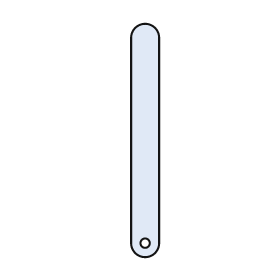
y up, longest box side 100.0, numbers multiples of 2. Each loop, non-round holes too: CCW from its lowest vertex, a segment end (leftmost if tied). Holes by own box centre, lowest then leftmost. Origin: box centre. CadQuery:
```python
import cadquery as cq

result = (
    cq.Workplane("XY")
    .moveTo(-6.0, -44.0)
    .threePointArc((0.0, -50.0), (6.0, -44.0))
    .lineTo(6.0, 44.0)
    .threePointArc((0.0, 50.0), (-6.0, 44.0))
    .close()
    .moveTo(0.0, -44.0)
    .circle(2.0)
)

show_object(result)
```